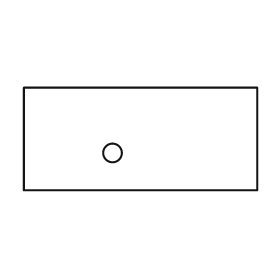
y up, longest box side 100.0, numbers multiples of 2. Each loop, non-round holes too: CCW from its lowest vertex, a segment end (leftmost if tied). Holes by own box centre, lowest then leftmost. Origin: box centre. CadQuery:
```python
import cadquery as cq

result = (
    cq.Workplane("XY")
    .moveTo(-50.0, -22.0)
    .lineTo(50.0, -22.0)
    .lineTo(50.0, 22.0)
    .lineTo(-50.0, 22.0)
    .close()
    .moveTo(-12.0, -6.0)
    .circle(4.0)
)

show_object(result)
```